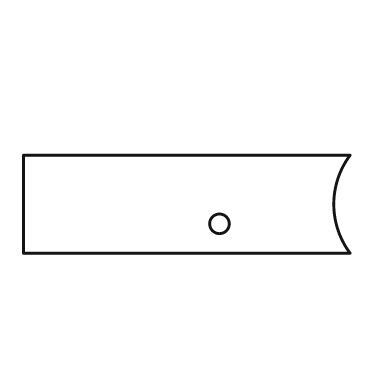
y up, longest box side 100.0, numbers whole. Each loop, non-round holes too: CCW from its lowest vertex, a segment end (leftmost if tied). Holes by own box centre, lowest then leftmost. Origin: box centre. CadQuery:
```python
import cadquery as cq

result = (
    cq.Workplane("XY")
    .moveTo(-50.0, -15.0)
    .lineTo(50.0, -15.0)
    .threePointArc((45.0, 0.0), (50.0, 15.0))
    .lineTo(-50.0, 15.0)
    .close()
    .moveTo(10.0, -6.0)
    .circle(3.0)
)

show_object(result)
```